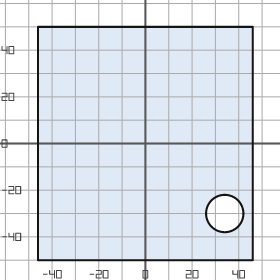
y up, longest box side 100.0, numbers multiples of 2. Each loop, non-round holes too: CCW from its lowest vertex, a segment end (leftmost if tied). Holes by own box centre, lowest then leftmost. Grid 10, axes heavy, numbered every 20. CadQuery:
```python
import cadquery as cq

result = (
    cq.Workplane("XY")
    .moveTo(-46.0, -50.0)
    .lineTo(46.0, -50.0)
    .lineTo(46.0, 50.0)
    .lineTo(-46.0, 50.0)
    .close()
    .moveTo(34.0, -30.0)
    .circle(8.0)
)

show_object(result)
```